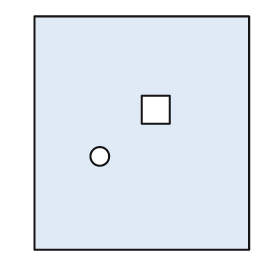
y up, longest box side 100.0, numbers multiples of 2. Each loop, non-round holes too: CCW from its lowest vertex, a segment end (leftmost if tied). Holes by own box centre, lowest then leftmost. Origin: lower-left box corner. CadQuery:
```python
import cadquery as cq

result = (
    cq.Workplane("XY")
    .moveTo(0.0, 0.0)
    .lineTo(92.0, 0.0)
    .lineTo(92.0, 100.0)
    .lineTo(0.0, 100.0)
    .close()
    .moveTo(28.0, 40.0)
    .circle(4.0)
    .moveTo(46.0, 54.0)
    .lineTo(58.0, 54.0)
    .lineTo(58.0, 66.0)
    .lineTo(46.0, 66.0)
    .close()
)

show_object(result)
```